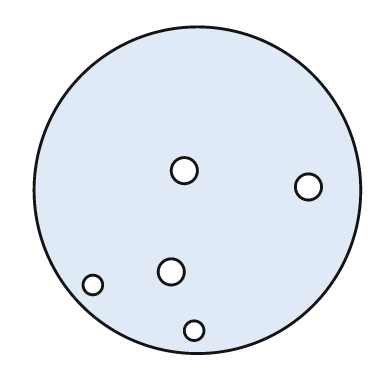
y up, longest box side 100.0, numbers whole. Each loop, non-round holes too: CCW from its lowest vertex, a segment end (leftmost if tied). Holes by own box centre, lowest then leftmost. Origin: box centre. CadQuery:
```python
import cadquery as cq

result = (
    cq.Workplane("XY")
    .moveTo(0.0, 0.0)
    .circle(50.0)
    .moveTo(-1.0, -43.0)
    .circle(3.0)
    .moveTo(-32.0, -29.0)
    .circle(3.0)
    .moveTo(-8.0, -25.0)
    .circle(4.0)
    .moveTo(34.0, 1.0)
    .circle(4.0)
    .moveTo(-4.0, 6.0)
    .circle(4.0)
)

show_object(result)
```